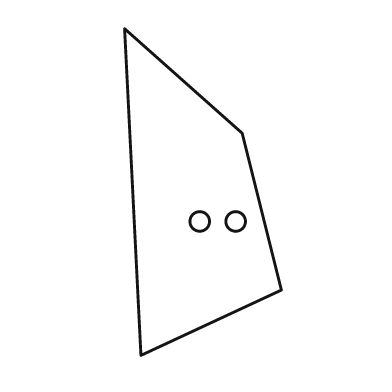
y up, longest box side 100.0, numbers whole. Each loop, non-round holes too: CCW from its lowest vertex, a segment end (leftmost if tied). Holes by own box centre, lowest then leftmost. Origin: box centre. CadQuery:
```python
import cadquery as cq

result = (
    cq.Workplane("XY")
    .moveTo(-19.0, -50.0)
    .lineTo(24.0, -30.0)
    .lineTo(12.0, 18.0)
    .lineTo(-24.0, 50.0)
    .close()
    .moveTo(-1.0, -9.0)
    .circle(3.0)
    .moveTo(10.0, -9.0)
    .circle(3.0)
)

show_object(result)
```